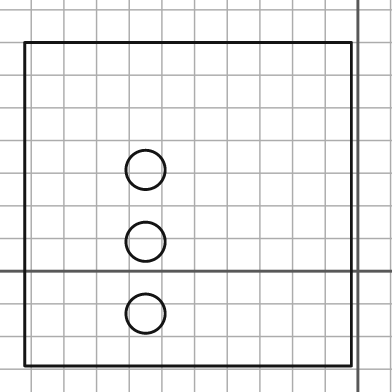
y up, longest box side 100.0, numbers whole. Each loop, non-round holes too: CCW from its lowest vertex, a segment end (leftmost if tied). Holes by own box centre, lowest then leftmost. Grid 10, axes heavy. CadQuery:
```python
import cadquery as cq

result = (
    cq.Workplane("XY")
    .moveTo(-102.0, -29.0)
    .lineTo(-2.0, -29.0)
    .lineTo(-2.0, 70.0)
    .lineTo(-102.0, 70.0)
    .close()
    .moveTo(-65.0, -13.0)
    .circle(6.0)
    .moveTo(-65.0, 9.0)
    .circle(6.0)
    .moveTo(-65.0, 31.0)
    .circle(6.0)
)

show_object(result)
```